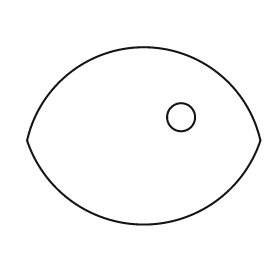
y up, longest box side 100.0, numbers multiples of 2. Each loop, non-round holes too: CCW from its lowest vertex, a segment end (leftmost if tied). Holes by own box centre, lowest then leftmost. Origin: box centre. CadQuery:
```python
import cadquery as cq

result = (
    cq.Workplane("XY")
    .moveTo(-50.0, -2.0)
    .threePointArc((0.0, -38.0), (50.0, -2.0))
    .threePointArc((0.0, 38.0), (-50.0, -2.0))
    .close()
    .moveTo(16.0, 8.0)
    .circle(6.0)
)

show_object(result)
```